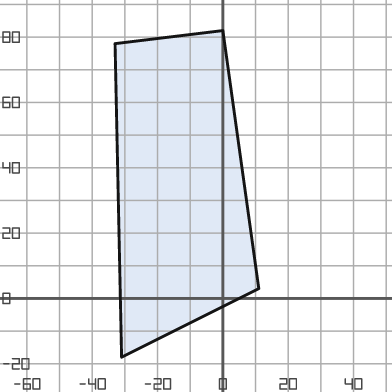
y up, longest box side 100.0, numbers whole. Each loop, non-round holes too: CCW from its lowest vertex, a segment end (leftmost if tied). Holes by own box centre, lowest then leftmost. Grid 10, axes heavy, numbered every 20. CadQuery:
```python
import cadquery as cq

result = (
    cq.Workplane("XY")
    .moveTo(-31.0, -18.0)
    .lineTo(11.0, 3.0)
    .lineTo(0.0, 82.0)
    .lineTo(-33.0, 78.0)
    .close()
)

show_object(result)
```